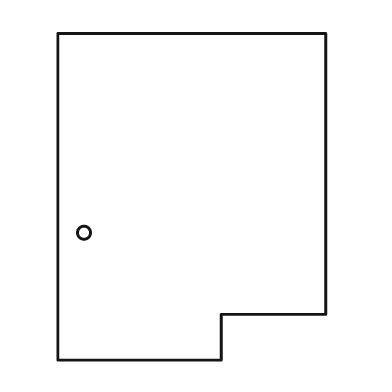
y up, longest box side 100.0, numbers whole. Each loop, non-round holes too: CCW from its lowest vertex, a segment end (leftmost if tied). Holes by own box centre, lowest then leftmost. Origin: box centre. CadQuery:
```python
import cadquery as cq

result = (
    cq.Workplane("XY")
    .moveTo(-41.0, -50.0)
    .lineTo(9.0, -50.0)
    .lineTo(9.0, -36.0)
    .lineTo(41.0, -36.0)
    .lineTo(41.0, 50.0)
    .lineTo(-41.0, 50.0)
    .close()
    .moveTo(-33.0, -11.0)
    .circle(2.0)
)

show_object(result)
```